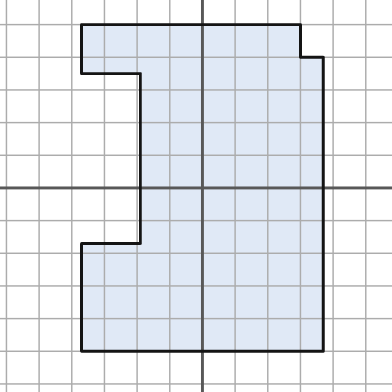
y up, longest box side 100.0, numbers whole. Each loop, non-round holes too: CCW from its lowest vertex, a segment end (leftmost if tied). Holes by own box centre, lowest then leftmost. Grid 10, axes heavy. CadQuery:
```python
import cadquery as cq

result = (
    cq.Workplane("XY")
    .moveTo(-37.0, -50.0)
    .lineTo(37.0, -50.0)
    .lineTo(37.0, 40.0)
    .lineTo(30.0, 40.0)
    .lineTo(30.0, 50.0)
    .lineTo(-37.0, 50.0)
    .lineTo(-37.0, 35.0)
    .lineTo(-19.0, 35.0)
    .lineTo(-19.0, -17.0)
    .lineTo(-37.0, -17.0)
    .close()
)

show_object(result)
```